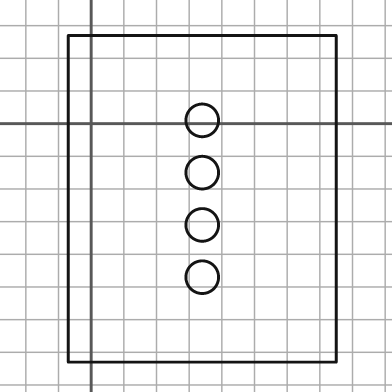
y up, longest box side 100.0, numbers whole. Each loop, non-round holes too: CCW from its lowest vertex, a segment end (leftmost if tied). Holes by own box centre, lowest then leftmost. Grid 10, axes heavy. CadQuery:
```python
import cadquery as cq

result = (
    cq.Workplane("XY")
    .moveTo(-7.0, -73.0)
    .lineTo(75.0, -73.0)
    .lineTo(75.0, 27.0)
    .lineTo(-7.0, 27.0)
    .close()
    .moveTo(34.0, -47.0)
    .circle(5.0)
    .moveTo(34.0, -31.0)
    .circle(5.0)
    .moveTo(34.0, -15.0)
    .circle(5.0)
    .moveTo(34.0, 1.0)
    .circle(5.0)
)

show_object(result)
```